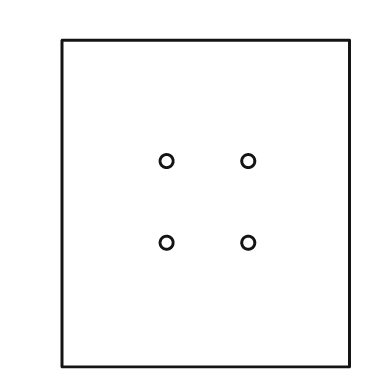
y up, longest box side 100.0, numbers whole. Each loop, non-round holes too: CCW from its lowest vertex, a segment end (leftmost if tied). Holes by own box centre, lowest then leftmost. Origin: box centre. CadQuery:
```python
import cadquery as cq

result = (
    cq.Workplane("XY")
    .moveTo(-44.0, -50.0)
    .lineTo(44.0, -50.0)
    .lineTo(44.0, 50.0)
    .lineTo(-44.0, 50.0)
    .close()
    .moveTo(-12.0, -12.0)
    .circle(2.0)
    .moveTo(13.0, -12.0)
    .circle(2.0)
    .moveTo(-12.0, 13.0)
    .circle(2.0)
    .moveTo(13.0, 13.0)
    .circle(2.0)
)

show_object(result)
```